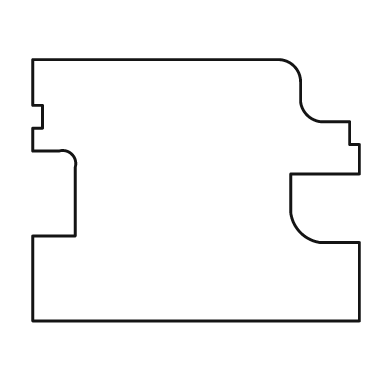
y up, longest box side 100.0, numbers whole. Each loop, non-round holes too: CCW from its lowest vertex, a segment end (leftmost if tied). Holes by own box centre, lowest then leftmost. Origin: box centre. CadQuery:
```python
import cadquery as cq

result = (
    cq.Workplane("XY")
    .moveTo(-50.0, -40.0)
    .lineTo(50.0, -40.0)
    .lineTo(50.0, -16.0)
    .lineTo(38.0, -16.0)
    .threePointArc((32.0, -13.0), (29.0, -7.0))
    .lineTo(29.0, 5.0)
    .lineTo(50.0, 5.0)
    .lineTo(50.0, 14.0)
    .lineTo(47.0, 14.0)
    .lineTo(47.0, 21.0)
    .lineTo(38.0, 21.0)
    .threePointArc((34.0, 23.0), (32.0, 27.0))
    .lineTo(32.0, 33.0)
    .threePointArc((30.0, 38.0), (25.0, 40.0))
    .lineTo(-50.0, 40.0)
    .lineTo(-50.0, 26.0)
    .lineTo(-47.0, 26.0)
    .lineTo(-47.0, 19.0)
    .lineTo(-50.0, 19.0)
    .lineTo(-50.0, 12.0)
    .lineTo(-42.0, 12.0)
    .threePointArc((-38.0, 11.0), (-37.0, 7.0))
    .lineTo(-37.0, -14.0)
    .lineTo(-50.0, -14.0)
    .close()
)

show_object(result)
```